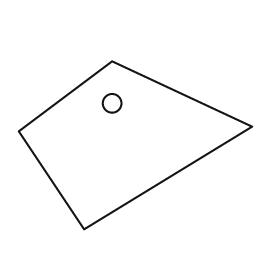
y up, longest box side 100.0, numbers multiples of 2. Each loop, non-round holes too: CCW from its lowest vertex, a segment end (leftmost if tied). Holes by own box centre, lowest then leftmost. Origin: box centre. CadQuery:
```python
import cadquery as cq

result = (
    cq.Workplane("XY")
    .moveTo(-22.0, -36.0)
    .lineTo(50.0, 8.0)
    .lineTo(-10.0, 36.0)
    .lineTo(-50.0, 6.0)
    .close()
    .moveTo(-10.0, 18.0)
    .circle(4.0)
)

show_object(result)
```